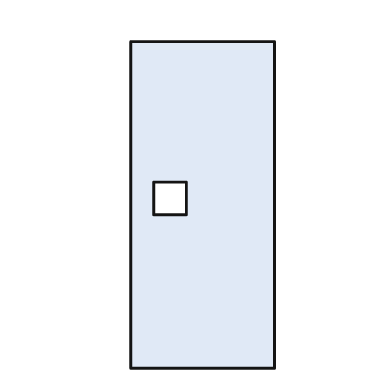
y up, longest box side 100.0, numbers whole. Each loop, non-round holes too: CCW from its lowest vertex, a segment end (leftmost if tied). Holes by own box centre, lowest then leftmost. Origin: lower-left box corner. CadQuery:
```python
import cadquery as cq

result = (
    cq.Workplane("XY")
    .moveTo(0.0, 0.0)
    .lineTo(44.0, 0.0)
    .lineTo(44.0, 100.0)
    .lineTo(0.0, 100.0)
    .close()
    .moveTo(7.0, 47.0)
    .lineTo(17.0, 47.0)
    .lineTo(17.0, 57.0)
    .lineTo(7.0, 57.0)
    .close()
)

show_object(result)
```